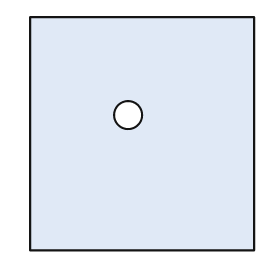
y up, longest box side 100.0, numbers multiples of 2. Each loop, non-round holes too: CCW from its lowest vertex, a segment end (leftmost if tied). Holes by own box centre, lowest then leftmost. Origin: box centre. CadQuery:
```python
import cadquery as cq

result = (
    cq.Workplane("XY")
    .moveTo(-48.0, -50.0)
    .lineTo(48.0, -50.0)
    .lineTo(48.0, 50.0)
    .lineTo(-48.0, 50.0)
    .close()
    .moveTo(-6.0, 8.0)
    .circle(6.0)
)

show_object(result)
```